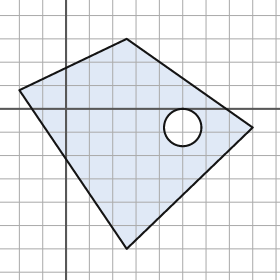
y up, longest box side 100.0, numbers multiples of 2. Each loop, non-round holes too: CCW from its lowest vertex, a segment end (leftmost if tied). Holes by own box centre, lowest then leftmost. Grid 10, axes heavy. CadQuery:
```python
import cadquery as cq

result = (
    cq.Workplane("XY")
    .moveTo(26.0, -60.0)
    .lineTo(80.0, -8.0)
    .lineTo(26.0, 30.0)
    .lineTo(-20.0, 8.0)
    .close()
    .moveTo(50.0, -8.0)
    .circle(8.0)
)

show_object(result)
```